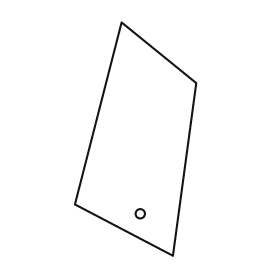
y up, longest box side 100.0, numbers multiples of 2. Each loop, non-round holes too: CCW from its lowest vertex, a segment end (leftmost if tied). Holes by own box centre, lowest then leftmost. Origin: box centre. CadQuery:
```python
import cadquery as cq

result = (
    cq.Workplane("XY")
    .moveTo(16.0, -50.0)
    .lineTo(26.0, 24.0)
    .lineTo(-6.0, 50.0)
    .lineTo(-26.0, -28.0)
    .close()
    .moveTo(2.0, -32.0)
    .circle(2.0)
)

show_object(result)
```